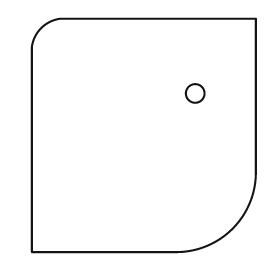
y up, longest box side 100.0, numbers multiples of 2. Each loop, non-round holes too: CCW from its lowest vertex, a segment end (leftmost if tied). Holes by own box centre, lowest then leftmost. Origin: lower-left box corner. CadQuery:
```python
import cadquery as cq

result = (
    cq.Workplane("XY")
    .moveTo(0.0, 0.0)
    .lineTo(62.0, 0.0)
    .threePointArc((86.0, 10.0), (96.0, 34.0))
    .lineTo(96.0, 100.0)
    .lineTo(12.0, 100.0)
    .threePointArc((4.0, 96.0), (0.0, 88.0))
    .close()
    .moveTo(70.0, 68.0)
    .circle(4.0)
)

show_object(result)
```